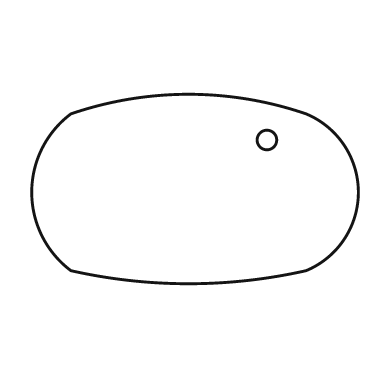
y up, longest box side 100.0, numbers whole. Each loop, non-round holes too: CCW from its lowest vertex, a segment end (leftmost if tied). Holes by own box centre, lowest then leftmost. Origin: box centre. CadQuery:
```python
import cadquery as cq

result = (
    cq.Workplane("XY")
    .moveTo(-38.0, -25.0)
    .threePointArc((-2.0, -29.0), (34.0, -25.0))
    .threePointArc((50.0, -1.0), (34.0, 23.0))
    .threePointArc((-2.0, 29.0), (-38.0, 23.0))
    .threePointArc((-50.0, -1.0), (-38.0, -25.0))
    .close()
    .moveTo(22.0, 15.0)
    .circle(3.0)
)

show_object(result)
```